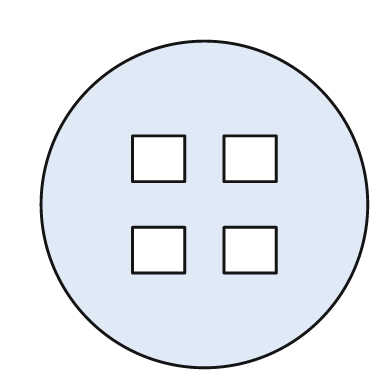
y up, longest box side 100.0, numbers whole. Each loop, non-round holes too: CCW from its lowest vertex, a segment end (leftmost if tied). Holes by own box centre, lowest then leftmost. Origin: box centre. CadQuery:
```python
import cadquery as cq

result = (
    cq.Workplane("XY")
    .moveTo(0.0, 0.0)
    .circle(50.0)
    .moveTo(-22.0, -21.0)
    .lineTo(-6.0, -21.0)
    .lineTo(-6.0, -7.0)
    .lineTo(-22.0, -7.0)
    .close()
    .moveTo(6.0, -21.0)
    .lineTo(22.0, -21.0)
    .lineTo(22.0, -7.0)
    .lineTo(6.0, -7.0)
    .close()
    .moveTo(-22.0, 7.0)
    .lineTo(-6.0, 7.0)
    .lineTo(-6.0, 21.0)
    .lineTo(-22.0, 21.0)
    .close()
    .moveTo(6.0, 7.0)
    .lineTo(22.0, 7.0)
    .lineTo(22.0, 21.0)
    .lineTo(6.0, 21.0)
    .close()
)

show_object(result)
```